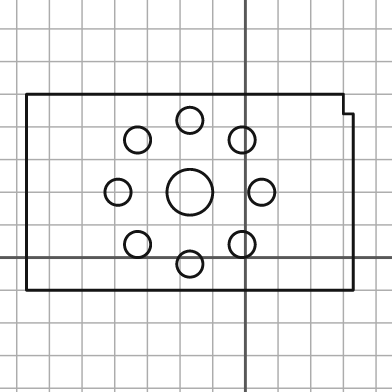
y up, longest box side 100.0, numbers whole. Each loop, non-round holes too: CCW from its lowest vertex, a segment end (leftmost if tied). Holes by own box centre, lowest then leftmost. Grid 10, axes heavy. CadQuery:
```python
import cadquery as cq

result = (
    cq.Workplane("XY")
    .moveTo(-67.0, -10.0)
    .lineTo(33.0, -10.0)
    .lineTo(33.0, 44.0)
    .lineTo(30.0, 44.0)
    .lineTo(30.0, 50.0)
    .lineTo(-67.0, 50.0)
    .close()
    .moveTo(-17.0, -2.0)
    .circle(4.0)
    .moveTo(-33.0, 4.0)
    .circle(4.0)
    .moveTo(-1.0, 4.0)
    .circle(4.0)
    .moveTo(-39.0, 20.0)
    .circle(4.0)
    .moveTo(-17.0, 20.0)
    .circle(7.0)
    .moveTo(5.0, 20.0)
    .circle(4.0)
    .moveTo(-33.0, 36.0)
    .circle(4.0)
    .moveTo(-1.0, 36.0)
    .circle(4.0)
    .moveTo(-17.0, 42.0)
    .circle(4.0)
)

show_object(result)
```